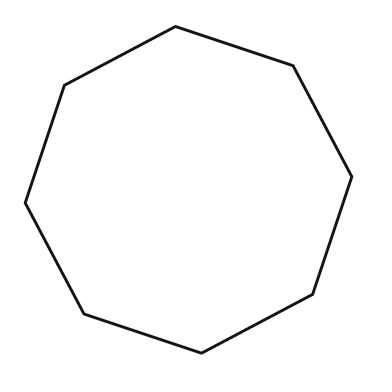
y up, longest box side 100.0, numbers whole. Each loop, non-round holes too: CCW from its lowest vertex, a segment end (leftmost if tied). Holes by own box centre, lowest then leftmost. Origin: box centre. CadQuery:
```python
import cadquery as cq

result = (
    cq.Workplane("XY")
    .moveTo(4.0, -50.0)
    .lineTo(38.0, -32.0)
    .lineTo(50.0, 4.0)
    .lineTo(32.0, 38.0)
    .lineTo(-4.0, 50.0)
    .lineTo(-38.0, 32.0)
    .lineTo(-50.0, -4.0)
    .lineTo(-32.0, -38.0)
    .close()
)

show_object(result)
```